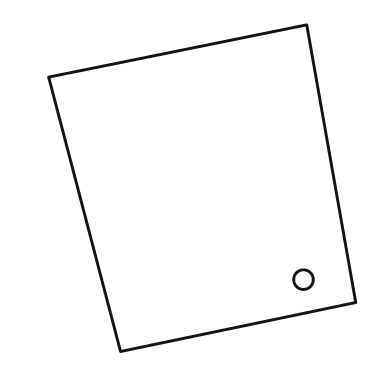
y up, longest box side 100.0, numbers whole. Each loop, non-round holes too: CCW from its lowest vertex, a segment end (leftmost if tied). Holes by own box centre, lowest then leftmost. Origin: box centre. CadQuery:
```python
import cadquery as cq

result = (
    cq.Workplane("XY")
    .moveTo(-25.0, -50.0)
    .lineTo(47.0, -35.0)
    .lineTo(32.0, 50.0)
    .lineTo(-47.0, 34.0)
    .close()
    .moveTo(31.0, -28.0)
    .circle(3.0)
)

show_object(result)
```